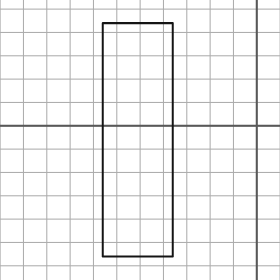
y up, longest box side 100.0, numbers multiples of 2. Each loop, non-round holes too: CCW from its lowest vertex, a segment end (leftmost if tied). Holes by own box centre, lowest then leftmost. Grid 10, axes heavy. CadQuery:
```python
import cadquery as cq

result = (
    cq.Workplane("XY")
    .moveTo(-66.0, -56.0)
    .lineTo(-36.0, -56.0)
    .lineTo(-36.0, 44.0)
    .lineTo(-66.0, 44.0)
    .close()
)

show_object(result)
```